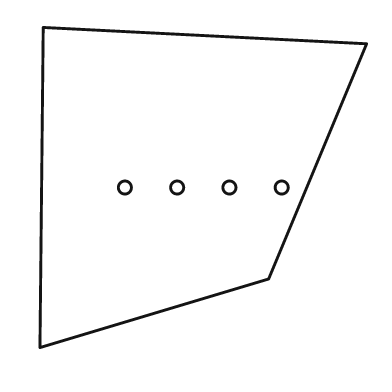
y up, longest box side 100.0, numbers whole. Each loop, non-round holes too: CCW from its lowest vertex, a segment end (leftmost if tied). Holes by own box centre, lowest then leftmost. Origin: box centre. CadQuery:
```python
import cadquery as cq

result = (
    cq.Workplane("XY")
    .moveTo(-50.0, -49.0)
    .lineTo(20.0, -28.0)
    .lineTo(50.0, 44.0)
    .lineTo(-49.0, 49.0)
    .close()
    .moveTo(-24.0, 0.0)
    .circle(2.0)
    .moveTo(-8.0, 0.0)
    .circle(2.0)
    .moveTo(8.0, 0.0)
    .circle(2.0)
    .moveTo(24.0, 0.0)
    .circle(2.0)
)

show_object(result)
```